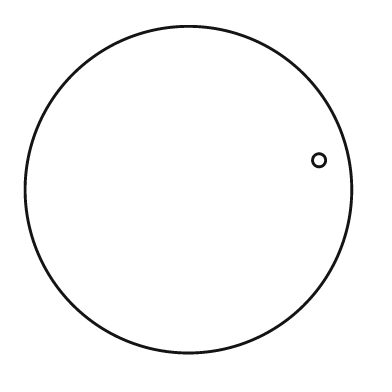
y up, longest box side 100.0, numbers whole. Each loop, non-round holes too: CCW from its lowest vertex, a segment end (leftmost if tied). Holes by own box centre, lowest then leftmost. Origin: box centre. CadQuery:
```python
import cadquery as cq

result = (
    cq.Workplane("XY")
    .moveTo(0.0, 0.0)
    .circle(50.0)
    .moveTo(40.0, 9.0)
    .circle(2.0)
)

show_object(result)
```